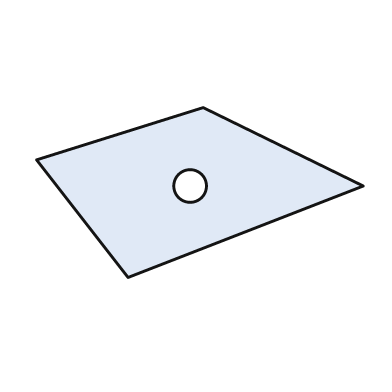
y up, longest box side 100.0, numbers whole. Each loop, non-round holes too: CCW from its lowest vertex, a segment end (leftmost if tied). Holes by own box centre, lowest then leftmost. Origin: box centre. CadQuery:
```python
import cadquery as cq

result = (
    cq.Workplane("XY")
    .moveTo(-22.0, -26.0)
    .lineTo(50.0, 2.0)
    .lineTo(1.0, 26.0)
    .lineTo(-50.0, 10.0)
    .close()
    .moveTo(-3.0, 2.0)
    .circle(5.0)
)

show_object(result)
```